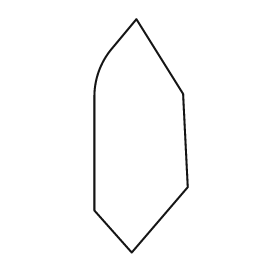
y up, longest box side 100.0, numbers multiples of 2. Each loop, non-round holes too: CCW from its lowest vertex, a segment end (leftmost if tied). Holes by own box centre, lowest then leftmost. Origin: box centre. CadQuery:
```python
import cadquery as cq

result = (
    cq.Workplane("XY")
    .moveTo(-4.0, -50.0)
    .lineTo(20.0, -22.0)
    .lineTo(18.0, 18.0)
    .lineTo(-2.0, 50.0)
    .lineTo(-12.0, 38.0)
    .threePointArc((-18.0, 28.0), (-20.0, 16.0))
    .lineTo(-20.0, -32.0)
    .close()
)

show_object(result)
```